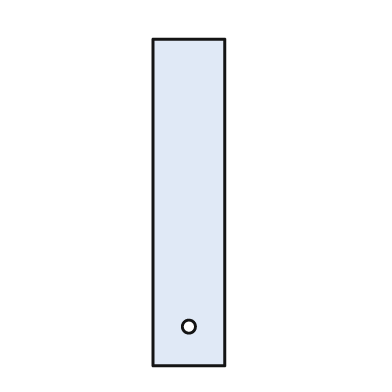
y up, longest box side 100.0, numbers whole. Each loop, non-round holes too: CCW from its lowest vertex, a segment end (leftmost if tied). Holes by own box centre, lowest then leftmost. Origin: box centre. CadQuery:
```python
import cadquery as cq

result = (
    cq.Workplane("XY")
    .moveTo(-11.0, -50.0)
    .lineTo(11.0, -50.0)
    .lineTo(11.0, 50.0)
    .lineTo(-11.0, 50.0)
    .close()
    .moveTo(0.0, -38.0)
    .circle(2.0)
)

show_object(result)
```